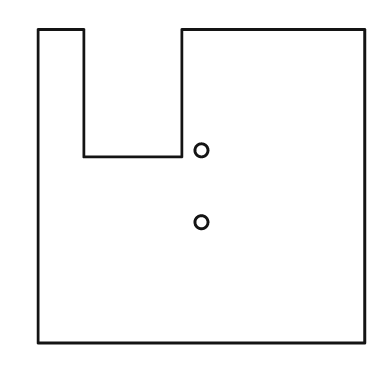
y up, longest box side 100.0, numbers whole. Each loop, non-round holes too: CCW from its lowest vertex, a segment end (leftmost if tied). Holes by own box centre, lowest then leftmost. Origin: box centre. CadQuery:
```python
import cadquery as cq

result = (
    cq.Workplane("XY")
    .moveTo(-50.0, -48.0)
    .lineTo(50.0, -48.0)
    .lineTo(50.0, 48.0)
    .lineTo(-6.0, 48.0)
    .lineTo(-6.0, 9.0)
    .lineTo(-36.0, 9.0)
    .lineTo(-36.0, 48.0)
    .lineTo(-50.0, 48.0)
    .close()
    .moveTo(0.0, -11.0)
    .circle(2.0)
    .moveTo(0.0, 11.0)
    .circle(2.0)
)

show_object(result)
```